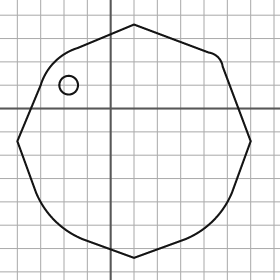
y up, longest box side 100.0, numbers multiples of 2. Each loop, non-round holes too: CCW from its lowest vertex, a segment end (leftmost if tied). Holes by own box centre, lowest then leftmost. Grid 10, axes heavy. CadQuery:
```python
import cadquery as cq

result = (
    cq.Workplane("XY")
    .moveTo(10.0, -64.0)
    .lineTo(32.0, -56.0)
    .threePointArc((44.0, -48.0), (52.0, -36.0))
    .lineTo(60.0, -14.0)
    .lineTo(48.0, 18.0)
    .threePointArc((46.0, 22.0), (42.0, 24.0))
    .lineTo(10.0, 36.0)
    .lineTo(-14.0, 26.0)
    .threePointArc((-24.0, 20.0), (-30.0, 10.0))
    .lineTo(-40.0, -14.0)
    .lineTo(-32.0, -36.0)
    .threePointArc((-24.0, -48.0), (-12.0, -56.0))
    .close()
    .moveTo(-18.0, 10.0)
    .circle(4.0)
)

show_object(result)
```